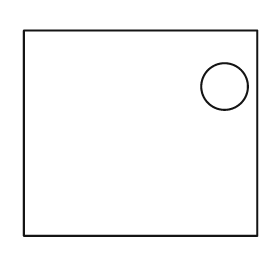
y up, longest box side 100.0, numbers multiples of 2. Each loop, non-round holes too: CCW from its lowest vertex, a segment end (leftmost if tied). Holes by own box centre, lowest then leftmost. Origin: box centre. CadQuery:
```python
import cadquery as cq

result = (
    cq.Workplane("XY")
    .moveTo(-50.0, -44.0)
    .lineTo(50.0, -44.0)
    .lineTo(50.0, 44.0)
    .lineTo(-50.0, 44.0)
    .close()
    .moveTo(36.0, 20.0)
    .circle(10.0)
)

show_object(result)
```